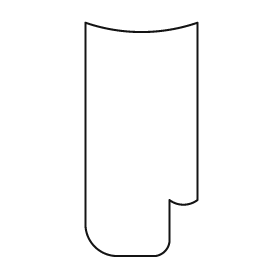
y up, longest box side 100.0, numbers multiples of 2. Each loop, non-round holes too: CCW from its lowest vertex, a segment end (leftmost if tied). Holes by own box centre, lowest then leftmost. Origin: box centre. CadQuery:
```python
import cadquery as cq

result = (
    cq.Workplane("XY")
    .moveTo(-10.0, -50.0)
    .lineTo(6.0, -50.0)
    .threePointArc((10.0, -48.0), (12.0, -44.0))
    .lineTo(12.0, -26.0)
    .threePointArc((18.0, -28.0), (24.0, -26.0))
    .lineTo(24.0, 50.0)
    .threePointArc((0.0, 46.0), (-24.0, 50.0))
    .lineTo(-24.0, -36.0)
    .threePointArc((-20.0, -46.0), (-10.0, -50.0))
    .close()
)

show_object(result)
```